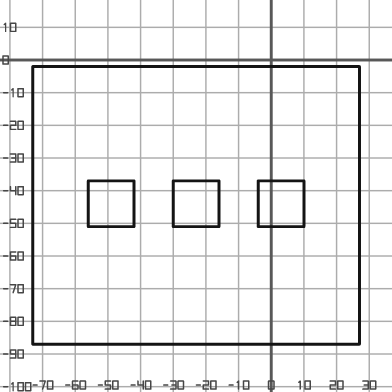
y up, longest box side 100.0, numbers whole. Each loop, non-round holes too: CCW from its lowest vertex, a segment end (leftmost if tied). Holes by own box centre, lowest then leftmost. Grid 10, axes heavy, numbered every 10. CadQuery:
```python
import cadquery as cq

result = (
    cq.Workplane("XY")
    .moveTo(-73.0, -87.0)
    .lineTo(27.0, -87.0)
    .lineTo(27.0, -2.0)
    .lineTo(-73.0, -2.0)
    .close()
    .moveTo(-56.0, -51.0)
    .lineTo(-42.0, -51.0)
    .lineTo(-42.0, -37.0)
    .lineTo(-56.0, -37.0)
    .close()
    .moveTo(-30.0, -51.0)
    .lineTo(-16.0, -51.0)
    .lineTo(-16.0, -37.0)
    .lineTo(-30.0, -37.0)
    .close()
    .moveTo(-4.0, -51.0)
    .lineTo(10.0, -51.0)
    .lineTo(10.0, -37.0)
    .lineTo(-4.0, -37.0)
    .close()
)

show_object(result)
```